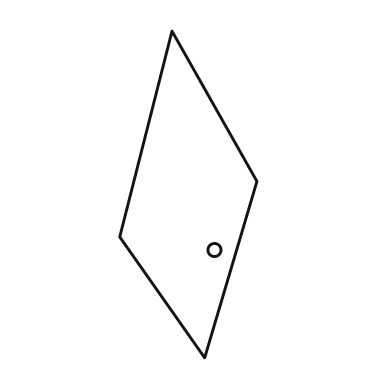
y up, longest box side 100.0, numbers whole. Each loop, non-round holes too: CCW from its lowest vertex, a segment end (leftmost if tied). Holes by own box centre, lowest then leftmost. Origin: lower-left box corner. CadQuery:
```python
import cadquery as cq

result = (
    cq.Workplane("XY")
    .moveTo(26.0, 0.0)
    .lineTo(42.0, 54.0)
    .lineTo(16.0, 100.0)
    .lineTo(0.0, 37.0)
    .close()
    .moveTo(29.0, 33.0)
    .circle(2.0)
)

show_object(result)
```